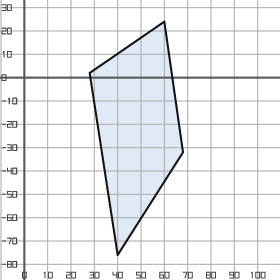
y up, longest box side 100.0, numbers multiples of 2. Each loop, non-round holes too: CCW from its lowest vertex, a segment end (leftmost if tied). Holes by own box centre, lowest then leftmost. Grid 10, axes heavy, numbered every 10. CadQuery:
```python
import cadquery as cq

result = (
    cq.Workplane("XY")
    .moveTo(40.0, -76.0)
    .lineTo(68.0, -32.0)
    .lineTo(60.0, 24.0)
    .lineTo(28.0, 2.0)
    .close()
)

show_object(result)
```